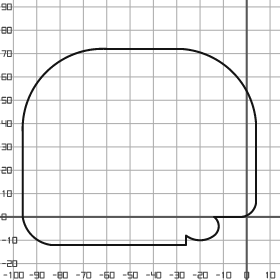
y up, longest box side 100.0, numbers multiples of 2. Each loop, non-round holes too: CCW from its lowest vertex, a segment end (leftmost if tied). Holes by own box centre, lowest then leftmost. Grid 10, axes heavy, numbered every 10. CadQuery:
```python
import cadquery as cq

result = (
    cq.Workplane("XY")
    .moveTo(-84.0, -12.0)
    .lineTo(-26.0, -12.0)
    .lineTo(-26.0, -8.0)
    .threePointArc((-20.0, -10.0), (-14.0, -8.0))
    .threePointArc((-12.0, -4.0), (-14.0, 0.0))
    .lineTo(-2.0, 0.0)
    .threePointArc((2.0, 2.0), (4.0, 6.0))
    .lineTo(4.0, 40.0)
    .threePointArc((-6.0, 62.0), (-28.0, 72.0))
    .lineTo(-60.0, 72.0)
    .threePointArc((-86.0, 62.0), (-96.0, 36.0))
    .lineTo(-96.0, 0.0)
    .threePointArc((-92.0, -8.0), (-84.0, -12.0))
    .close()
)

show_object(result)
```